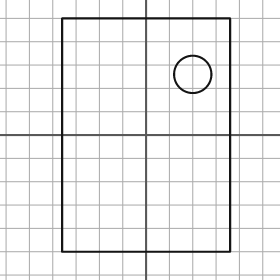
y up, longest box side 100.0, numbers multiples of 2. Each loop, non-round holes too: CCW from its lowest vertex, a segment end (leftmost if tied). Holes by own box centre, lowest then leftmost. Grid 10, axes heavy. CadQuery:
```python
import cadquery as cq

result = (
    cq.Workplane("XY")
    .moveTo(-36.0, -50.0)
    .lineTo(36.0, -50.0)
    .lineTo(36.0, 50.0)
    .lineTo(-36.0, 50.0)
    .close()
    .moveTo(20.0, 26.0)
    .circle(8.0)
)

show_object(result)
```